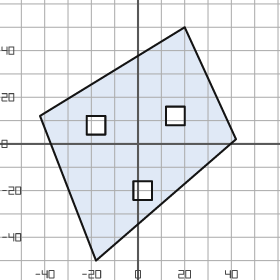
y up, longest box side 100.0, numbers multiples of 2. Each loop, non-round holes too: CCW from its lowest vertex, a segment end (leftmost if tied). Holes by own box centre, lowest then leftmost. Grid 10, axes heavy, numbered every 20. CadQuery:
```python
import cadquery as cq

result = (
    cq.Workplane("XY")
    .moveTo(-18.0, -50.0)
    .lineTo(42.0, 2.0)
    .lineTo(20.0, 50.0)
    .lineTo(-42.0, 12.0)
    .close()
    .moveTo(-2.0, -24.0)
    .lineTo(6.0, -24.0)
    .lineTo(6.0, -16.0)
    .lineTo(-2.0, -16.0)
    .close()
    .moveTo(-22.0, 4.0)
    .lineTo(-14.0, 4.0)
    .lineTo(-14.0, 12.0)
    .lineTo(-22.0, 12.0)
    .close()
    .moveTo(12.0, 8.0)
    .lineTo(20.0, 8.0)
    .lineTo(20.0, 16.0)
    .lineTo(12.0, 16.0)
    .close()
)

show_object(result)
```